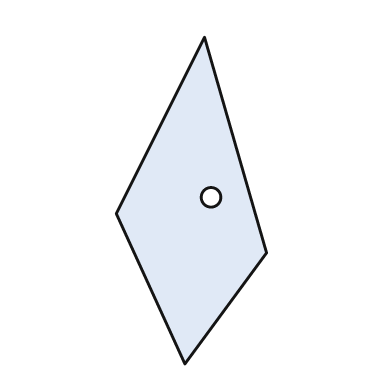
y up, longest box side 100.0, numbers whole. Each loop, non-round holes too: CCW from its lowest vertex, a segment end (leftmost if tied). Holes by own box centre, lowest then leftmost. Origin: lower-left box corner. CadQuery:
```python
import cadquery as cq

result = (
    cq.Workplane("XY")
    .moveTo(21.0, 0.0)
    .lineTo(46.0, 34.0)
    .lineTo(27.0, 100.0)
    .lineTo(0.0, 46.0)
    .close()
    .moveTo(29.0, 51.0)
    .circle(3.0)
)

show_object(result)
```